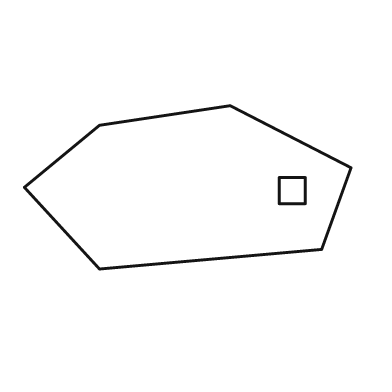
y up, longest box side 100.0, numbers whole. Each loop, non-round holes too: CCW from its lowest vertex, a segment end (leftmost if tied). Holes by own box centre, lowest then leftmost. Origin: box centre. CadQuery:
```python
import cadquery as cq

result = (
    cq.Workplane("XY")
    .moveTo(-27.0, -25.0)
    .lineTo(41.0, -19.0)
    .lineTo(50.0, 6.0)
    .lineTo(13.0, 25.0)
    .lineTo(-27.0, 19.0)
    .lineTo(-50.0, 0.0)
    .close()
    .moveTo(28.0, -5.0)
    .lineTo(36.0, -5.0)
    .lineTo(36.0, 3.0)
    .lineTo(28.0, 3.0)
    .close()
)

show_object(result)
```